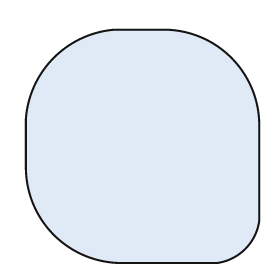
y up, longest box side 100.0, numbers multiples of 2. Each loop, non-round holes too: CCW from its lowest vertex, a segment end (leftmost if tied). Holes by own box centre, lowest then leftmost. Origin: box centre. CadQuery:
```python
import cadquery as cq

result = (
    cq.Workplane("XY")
    .moveTo(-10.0, -50.0)
    .lineTo(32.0, -50.0)
    .threePointArc((44.0, -44.0), (50.0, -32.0))
    .lineTo(50.0, 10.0)
    .threePointArc((38.0, 38.0), (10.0, 50.0))
    .lineTo(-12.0, 50.0)
    .threePointArc((-38.0, 38.0), (-50.0, 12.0))
    .lineTo(-50.0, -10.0)
    .threePointArc((-38.0, -38.0), (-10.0, -50.0))
    .close()
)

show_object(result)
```